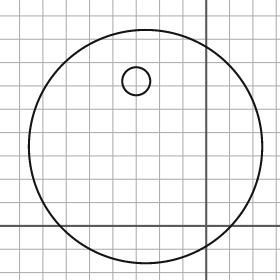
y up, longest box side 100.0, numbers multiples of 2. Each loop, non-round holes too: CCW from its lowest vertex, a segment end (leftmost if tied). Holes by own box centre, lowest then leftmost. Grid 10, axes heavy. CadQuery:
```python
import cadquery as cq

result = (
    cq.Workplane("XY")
    .moveTo(-26.0, 34.0)
    .circle(50.0)
    .moveTo(-30.0, 62.0)
    .circle(6.0)
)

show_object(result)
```